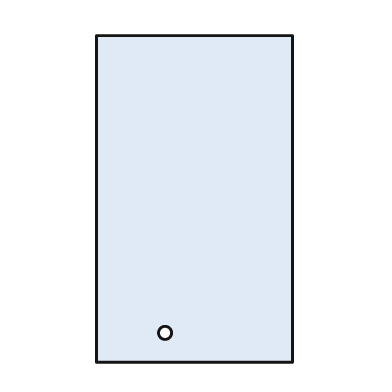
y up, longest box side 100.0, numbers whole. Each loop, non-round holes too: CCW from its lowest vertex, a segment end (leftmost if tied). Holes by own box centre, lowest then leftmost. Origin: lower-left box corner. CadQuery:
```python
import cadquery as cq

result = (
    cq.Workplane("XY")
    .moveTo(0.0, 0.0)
    .lineTo(60.0, 0.0)
    .lineTo(60.0, 100.0)
    .lineTo(0.0, 100.0)
    .close()
    .moveTo(21.0, 9.0)
    .circle(2.0)
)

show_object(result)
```